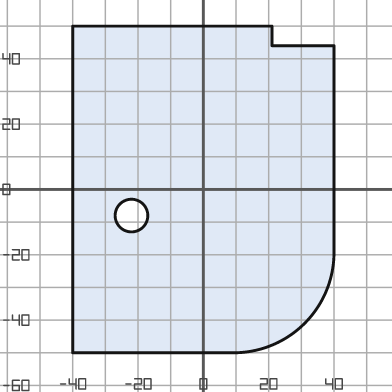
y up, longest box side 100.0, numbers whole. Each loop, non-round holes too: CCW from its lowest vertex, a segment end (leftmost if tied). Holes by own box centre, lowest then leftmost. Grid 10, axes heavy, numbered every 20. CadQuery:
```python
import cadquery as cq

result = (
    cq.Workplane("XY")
    .moveTo(-40.0, -50.0)
    .lineTo(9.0, -50.0)
    .threePointArc((31.0, -41.0), (40.0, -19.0))
    .lineTo(40.0, 44.0)
    .lineTo(21.0, 44.0)
    .lineTo(21.0, 50.0)
    .lineTo(-40.0, 50.0)
    .close()
    .moveTo(-22.0, -8.0)
    .circle(5.0)
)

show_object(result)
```